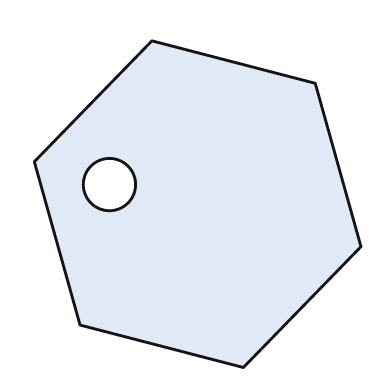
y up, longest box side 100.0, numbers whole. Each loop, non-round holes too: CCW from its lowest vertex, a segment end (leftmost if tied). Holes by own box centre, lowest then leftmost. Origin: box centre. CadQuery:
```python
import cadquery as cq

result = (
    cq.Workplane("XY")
    .moveTo(14.0, -50.0)
    .lineTo(50.0, -13.0)
    .lineTo(36.0, 37.0)
    .lineTo(-14.0, 50.0)
    .lineTo(-50.0, 13.0)
    .lineTo(-36.0, -37.0)
    .close()
    .moveTo(-27.0, 6.0)
    .circle(8.0)
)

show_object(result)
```